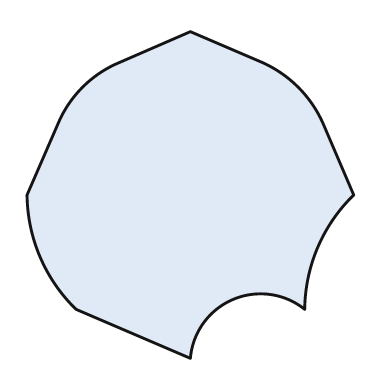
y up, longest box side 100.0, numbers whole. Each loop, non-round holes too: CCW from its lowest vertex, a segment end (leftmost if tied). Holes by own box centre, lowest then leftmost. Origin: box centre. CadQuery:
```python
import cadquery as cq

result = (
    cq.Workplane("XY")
    .moveTo(0.0, -50.0)
    .threePointArc((13.0, -32.0), (35.0, -35.0))
    .threePointArc((39.0, -16.0), (50.0, 0.0))
    .lineTo(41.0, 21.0)
    .threePointArc((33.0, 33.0), (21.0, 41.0))
    .lineTo(0.0, 50.0)
    .lineTo(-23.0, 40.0)
    .threePointArc((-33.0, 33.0), (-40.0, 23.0))
    .lineTo(-50.0, 0.0)
    .threePointArc((-46.0, -19.0), (-35.0, -35.0))
    .close()
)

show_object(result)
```